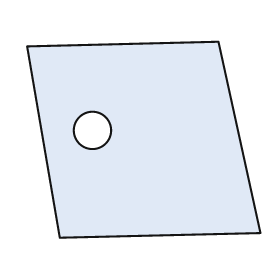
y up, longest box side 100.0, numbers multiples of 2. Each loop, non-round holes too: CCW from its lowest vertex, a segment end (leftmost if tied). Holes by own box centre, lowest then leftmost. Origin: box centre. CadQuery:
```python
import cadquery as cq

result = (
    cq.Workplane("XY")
    .moveTo(-36.0, -42.0)
    .lineTo(50.0, -40.0)
    .lineTo(32.0, 42.0)
    .lineTo(-50.0, 40.0)
    .close()
    .moveTo(-22.0, 4.0)
    .circle(8.0)
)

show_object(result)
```